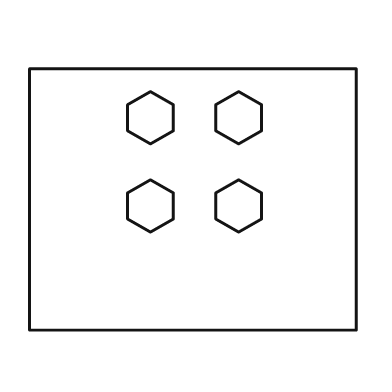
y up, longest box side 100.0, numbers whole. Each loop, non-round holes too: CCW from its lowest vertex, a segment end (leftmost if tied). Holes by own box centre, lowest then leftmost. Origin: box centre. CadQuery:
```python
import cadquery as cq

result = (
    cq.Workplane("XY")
    .moveTo(-50.0, -40.0)
    .lineTo(50.0, -40.0)
    .lineTo(50.0, 40.0)
    .lineTo(-50.0, 40.0)
    .close()
    .moveTo(-13.0, -10.0)
    .lineTo(-6.0, -6.0)
    .lineTo(-6.0, 2.0)
    .lineTo(-13.0, 6.0)
    .lineTo(-20.0, 2.0)
    .lineTo(-20.0, -6.0)
    .close()
    .moveTo(14.0, -10.0)
    .lineTo(21.0, -6.0)
    .lineTo(21.0, 2.0)
    .lineTo(14.0, 6.0)
    .lineTo(7.0, 2.0)
    .lineTo(7.0, -6.0)
    .close()
    .moveTo(-13.0, 17.0)
    .lineTo(-6.0, 21.0)
    .lineTo(-6.0, 29.0)
    .lineTo(-13.0, 33.0)
    .lineTo(-20.0, 29.0)
    .lineTo(-20.0, 21.0)
    .close()
    .moveTo(14.0, 17.0)
    .lineTo(21.0, 21.0)
    .lineTo(21.0, 29.0)
    .lineTo(14.0, 33.0)
    .lineTo(7.0, 29.0)
    .lineTo(7.0, 21.0)
    .close()
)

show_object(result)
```